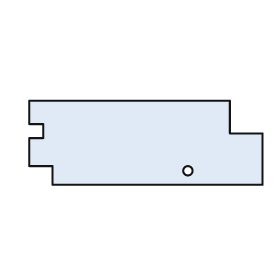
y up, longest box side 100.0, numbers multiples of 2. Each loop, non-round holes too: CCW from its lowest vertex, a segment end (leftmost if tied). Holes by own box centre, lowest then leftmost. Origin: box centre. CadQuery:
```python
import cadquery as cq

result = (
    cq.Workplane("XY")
    .moveTo(-40.0, -18.0)
    .lineTo(50.0, -18.0)
    .lineTo(50.0, 4.0)
    .lineTo(36.0, 4.0)
    .lineTo(36.0, 18.0)
    .lineTo(-50.0, 18.0)
    .lineTo(-50.0, 8.0)
    .lineTo(-44.0, 8.0)
    .lineTo(-44.0, 2.0)
    .lineTo(-50.0, 2.0)
    .lineTo(-50.0, -10.0)
    .lineTo(-40.0, -10.0)
    .close()
    .moveTo(18.0, -12.0)
    .circle(2.0)
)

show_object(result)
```